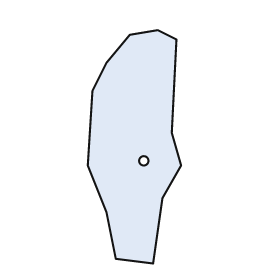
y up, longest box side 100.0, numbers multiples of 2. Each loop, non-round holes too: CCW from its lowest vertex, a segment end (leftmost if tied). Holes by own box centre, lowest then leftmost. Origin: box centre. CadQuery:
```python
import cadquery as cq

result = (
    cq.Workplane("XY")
    .moveTo(8.0, -50.0)
    .lineTo(12.0, -22.0)
    .lineTo(20.0, -8.0)
    .lineTo(16.0, 6.0)
    .lineTo(18.0, 46.0)
    .lineTo(10.0, 50.0)
    .lineTo(-2.0, 48.0)
    .lineTo(-12.0, 36.0)
    .lineTo(-18.0, 24.0)
    .lineTo(-20.0, -8.0)
    .lineTo(-12.0, -28.0)
    .lineTo(-8.0, -48.0)
    .close()
    .moveTo(4.0, -6.0)
    .circle(2.0)
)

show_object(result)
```